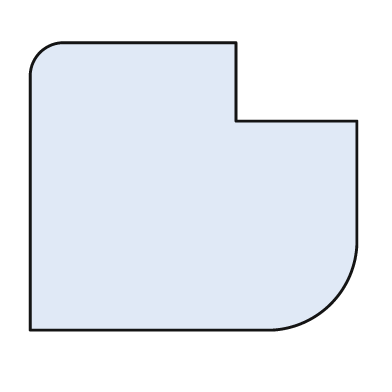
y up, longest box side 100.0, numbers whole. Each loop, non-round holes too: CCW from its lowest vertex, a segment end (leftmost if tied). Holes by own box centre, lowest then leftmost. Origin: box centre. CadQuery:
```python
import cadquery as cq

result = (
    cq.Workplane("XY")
    .moveTo(-50.0, -44.0)
    .lineTo(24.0, -44.0)
    .threePointArc((42.0, -36.0), (50.0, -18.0))
    .lineTo(50.0, 20.0)
    .lineTo(13.0, 20.0)
    .lineTo(13.0, 44.0)
    .lineTo(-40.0, 44.0)
    .threePointArc((-47.0, 41.0), (-50.0, 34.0))
    .close()
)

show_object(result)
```